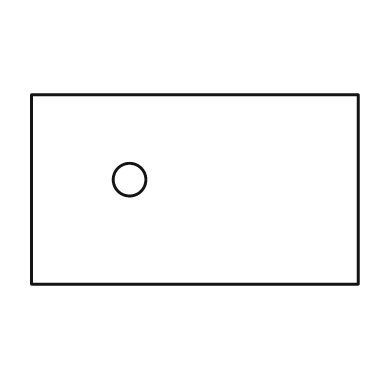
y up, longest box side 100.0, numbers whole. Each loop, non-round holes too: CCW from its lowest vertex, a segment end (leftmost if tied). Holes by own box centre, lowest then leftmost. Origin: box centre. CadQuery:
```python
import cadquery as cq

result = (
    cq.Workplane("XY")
    .moveTo(-50.0, -29.0)
    .lineTo(50.0, -29.0)
    .lineTo(50.0, 29.0)
    .lineTo(-50.0, 29.0)
    .close()
    .moveTo(-20.0, 3.0)
    .circle(5.0)
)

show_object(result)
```